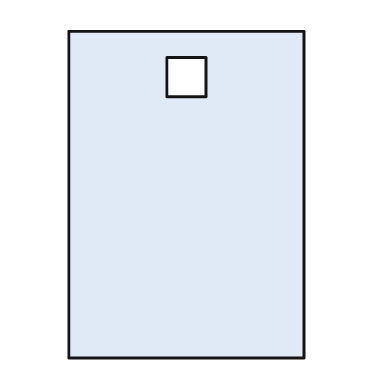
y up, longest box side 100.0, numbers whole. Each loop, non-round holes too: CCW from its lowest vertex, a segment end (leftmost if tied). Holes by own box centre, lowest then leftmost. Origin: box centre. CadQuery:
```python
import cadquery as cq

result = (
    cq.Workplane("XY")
    .moveTo(-36.0, -50.0)
    .lineTo(36.0, -50.0)
    .lineTo(36.0, 50.0)
    .lineTo(-36.0, 50.0)
    .close()
    .moveTo(-6.0, 30.0)
    .lineTo(6.0, 30.0)
    .lineTo(6.0, 42.0)
    .lineTo(-6.0, 42.0)
    .close()
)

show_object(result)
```